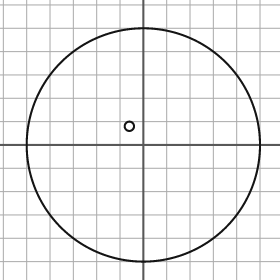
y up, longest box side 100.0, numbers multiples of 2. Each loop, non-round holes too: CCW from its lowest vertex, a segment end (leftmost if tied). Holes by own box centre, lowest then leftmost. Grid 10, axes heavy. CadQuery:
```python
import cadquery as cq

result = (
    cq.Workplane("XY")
    .moveTo(0.0, 0.0)
    .circle(50.0)
    .moveTo(-6.0, 8.0)
    .circle(2.0)
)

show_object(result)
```